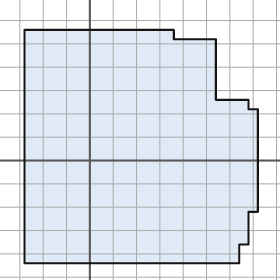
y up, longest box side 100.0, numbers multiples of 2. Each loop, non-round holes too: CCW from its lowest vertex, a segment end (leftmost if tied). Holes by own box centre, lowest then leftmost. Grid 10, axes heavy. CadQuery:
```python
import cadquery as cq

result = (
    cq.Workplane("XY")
    .moveTo(-28.0, -44.0)
    .lineTo(64.0, -44.0)
    .lineTo(64.0, -36.0)
    .lineTo(68.0, -36.0)
    .lineTo(68.0, -22.0)
    .lineTo(72.0, -22.0)
    .lineTo(72.0, 22.0)
    .lineTo(68.0, 22.0)
    .lineTo(68.0, 26.0)
    .lineTo(54.0, 26.0)
    .lineTo(54.0, 52.0)
    .lineTo(36.0, 52.0)
    .lineTo(36.0, 56.0)
    .lineTo(-28.0, 56.0)
    .close()
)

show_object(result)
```